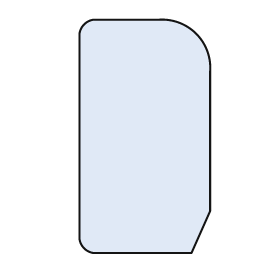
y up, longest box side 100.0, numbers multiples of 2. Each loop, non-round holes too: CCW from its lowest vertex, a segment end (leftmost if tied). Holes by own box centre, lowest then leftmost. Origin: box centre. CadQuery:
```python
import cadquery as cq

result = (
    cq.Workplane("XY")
    .moveTo(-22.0, -50.0)
    .lineTo(20.0, -50.0)
    .lineTo(28.0, -32.0)
    .lineTo(28.0, 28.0)
    .threePointArc((22.0, 44.0), (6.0, 50.0))
    .lineTo(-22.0, 50.0)
    .threePointArc((-26.0, 48.0), (-28.0, 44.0))
    .lineTo(-28.0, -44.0)
    .threePointArc((-26.0, -48.0), (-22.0, -50.0))
    .close()
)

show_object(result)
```